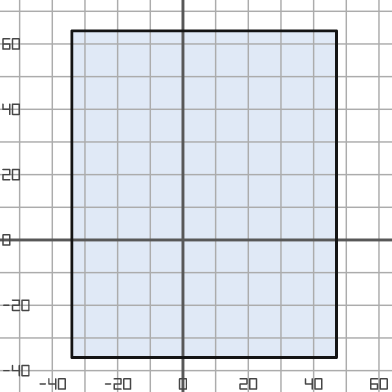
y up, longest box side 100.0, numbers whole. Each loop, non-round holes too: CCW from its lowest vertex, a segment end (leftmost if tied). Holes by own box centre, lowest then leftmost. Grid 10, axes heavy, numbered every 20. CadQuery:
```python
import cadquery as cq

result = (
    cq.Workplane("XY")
    .moveTo(-34.0, -36.0)
    .lineTo(47.0, -36.0)
    .lineTo(47.0, 64.0)
    .lineTo(-34.0, 64.0)
    .close()
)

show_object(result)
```